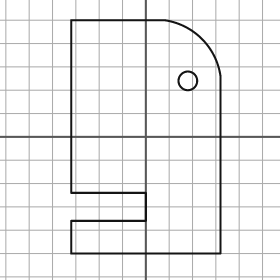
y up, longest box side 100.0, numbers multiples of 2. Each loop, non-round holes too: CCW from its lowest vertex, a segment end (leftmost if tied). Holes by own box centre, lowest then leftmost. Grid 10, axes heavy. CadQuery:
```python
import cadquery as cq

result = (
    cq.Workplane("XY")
    .moveTo(-32.0, -50.0)
    .lineTo(32.0, -50.0)
    .lineTo(32.0, 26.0)
    .threePointArc((24.0, 42.0), (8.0, 50.0))
    .lineTo(-32.0, 50.0)
    .lineTo(-32.0, -24.0)
    .lineTo(0.0, -24.0)
    .lineTo(0.0, -36.0)
    .lineTo(-32.0, -36.0)
    .close()
    .moveTo(18.0, 24.0)
    .circle(4.0)
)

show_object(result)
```